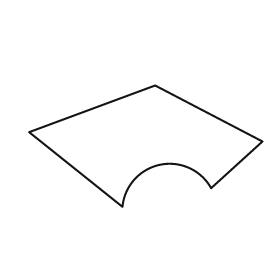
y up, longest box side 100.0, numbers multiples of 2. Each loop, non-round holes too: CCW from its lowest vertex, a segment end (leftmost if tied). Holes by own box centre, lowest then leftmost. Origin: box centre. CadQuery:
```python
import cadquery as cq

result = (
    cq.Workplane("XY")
    .moveTo(-10.0, -26.0)
    .threePointArc((6.0, -8.0), (28.0, -18.0))
    .lineTo(50.0, 2.0)
    .lineTo(4.0, 26.0)
    .lineTo(-50.0, 6.0)
    .close()
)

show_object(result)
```